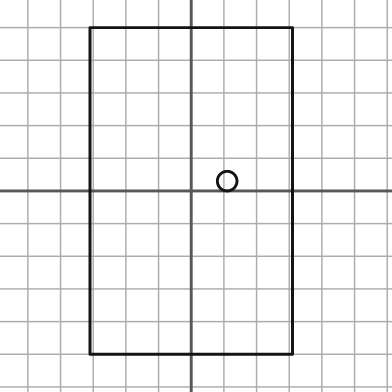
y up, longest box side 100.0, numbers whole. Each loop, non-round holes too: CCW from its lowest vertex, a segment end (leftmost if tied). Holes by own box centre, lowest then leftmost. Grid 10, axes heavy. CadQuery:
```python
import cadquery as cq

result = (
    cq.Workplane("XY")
    .moveTo(-31.0, -50.0)
    .lineTo(31.0, -50.0)
    .lineTo(31.0, 50.0)
    .lineTo(-31.0, 50.0)
    .close()
    .moveTo(11.0, 3.0)
    .circle(3.0)
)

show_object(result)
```